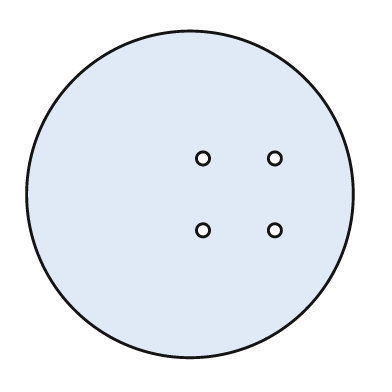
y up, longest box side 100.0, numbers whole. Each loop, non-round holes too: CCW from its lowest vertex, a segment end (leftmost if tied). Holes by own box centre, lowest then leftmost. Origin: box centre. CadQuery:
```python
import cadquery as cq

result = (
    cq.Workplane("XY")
    .moveTo(0.0, 0.0)
    .circle(50.0)
    .moveTo(4.0, -11.0)
    .circle(2.0)
    .moveTo(26.0, -11.0)
    .circle(2.0)
    .moveTo(4.0, 11.0)
    .circle(2.0)
    .moveTo(26.0, 11.0)
    .circle(2.0)
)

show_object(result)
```